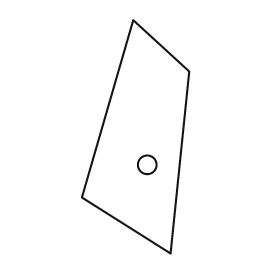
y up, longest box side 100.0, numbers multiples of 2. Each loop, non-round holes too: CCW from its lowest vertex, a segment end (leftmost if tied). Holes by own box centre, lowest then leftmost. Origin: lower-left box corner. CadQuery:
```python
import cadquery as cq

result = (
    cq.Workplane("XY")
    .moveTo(38.0, 0.0)
    .lineTo(46.0, 78.0)
    .lineTo(22.0, 100.0)
    .lineTo(0.0, 24.0)
    .close()
    .moveTo(28.0, 38.0)
    .circle(4.0)
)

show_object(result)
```